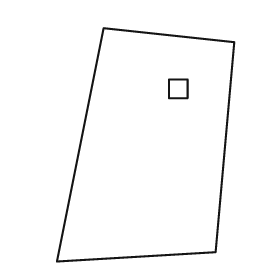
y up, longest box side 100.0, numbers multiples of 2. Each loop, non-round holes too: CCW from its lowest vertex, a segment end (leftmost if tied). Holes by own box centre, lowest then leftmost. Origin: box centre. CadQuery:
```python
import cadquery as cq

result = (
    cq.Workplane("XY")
    .moveTo(-38.0, -50.0)
    .lineTo(30.0, -46.0)
    .lineTo(38.0, 44.0)
    .lineTo(-18.0, 50.0)
    .close()
    .moveTo(10.0, 20.0)
    .lineTo(18.0, 20.0)
    .lineTo(18.0, 28.0)
    .lineTo(10.0, 28.0)
    .close()
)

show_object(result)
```